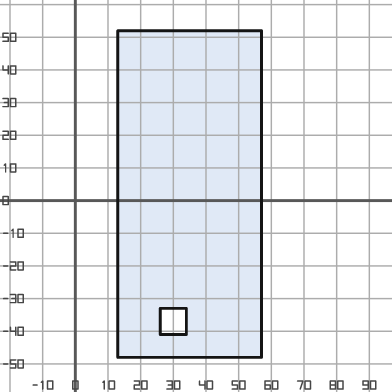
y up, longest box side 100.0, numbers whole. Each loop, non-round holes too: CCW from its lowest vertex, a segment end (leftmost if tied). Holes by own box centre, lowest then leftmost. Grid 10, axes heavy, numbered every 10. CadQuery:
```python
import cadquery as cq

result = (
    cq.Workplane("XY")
    .moveTo(13.0, -48.0)
    .lineTo(57.0, -48.0)
    .lineTo(57.0, 52.0)
    .lineTo(13.0, 52.0)
    .close()
    .moveTo(26.0, -41.0)
    .lineTo(34.0, -41.0)
    .lineTo(34.0, -33.0)
    .lineTo(26.0, -33.0)
    .close()
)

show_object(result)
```